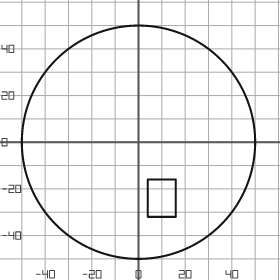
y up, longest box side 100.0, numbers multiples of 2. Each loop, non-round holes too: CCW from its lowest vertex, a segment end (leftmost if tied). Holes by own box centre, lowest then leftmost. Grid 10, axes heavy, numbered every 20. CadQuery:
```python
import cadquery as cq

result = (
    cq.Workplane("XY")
    .moveTo(0.0, 0.0)
    .circle(50.0)
    .moveTo(4.0, -32.0)
    .lineTo(16.0, -32.0)
    .lineTo(16.0, -16.0)
    .lineTo(4.0, -16.0)
    .close()
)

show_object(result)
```